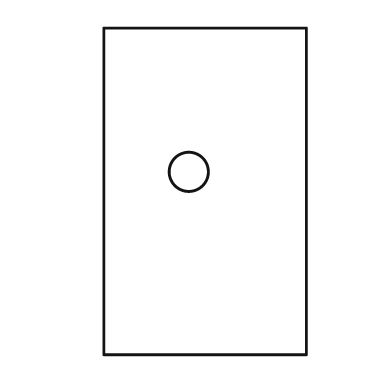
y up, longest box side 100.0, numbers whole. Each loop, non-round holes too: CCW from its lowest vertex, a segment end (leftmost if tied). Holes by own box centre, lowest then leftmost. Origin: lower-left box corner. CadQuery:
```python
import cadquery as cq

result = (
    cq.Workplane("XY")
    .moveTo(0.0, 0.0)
    .lineTo(62.0, 0.0)
    .lineTo(62.0, 100.0)
    .lineTo(0.0, 100.0)
    .close()
    .moveTo(26.0, 56.0)
    .circle(6.0)
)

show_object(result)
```